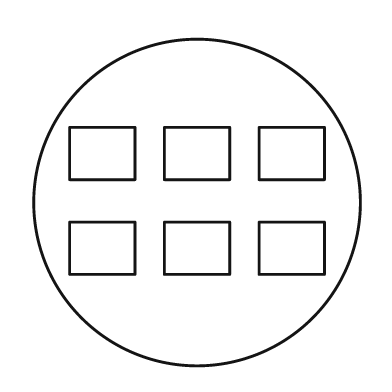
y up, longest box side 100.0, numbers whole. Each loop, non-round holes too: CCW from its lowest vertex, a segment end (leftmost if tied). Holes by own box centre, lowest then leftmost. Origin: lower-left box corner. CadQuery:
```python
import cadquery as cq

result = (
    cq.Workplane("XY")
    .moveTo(50.0, 50.0)
    .circle(50.0)
    .moveTo(11.0, 28.0)
    .lineTo(31.0, 28.0)
    .lineTo(31.0, 44.0)
    .lineTo(11.0, 44.0)
    .close()
    .moveTo(40.0, 28.0)
    .lineTo(60.0, 28.0)
    .lineTo(60.0, 44.0)
    .lineTo(40.0, 44.0)
    .close()
    .moveTo(69.0, 28.0)
    .lineTo(89.0, 28.0)
    .lineTo(89.0, 44.0)
    .lineTo(69.0, 44.0)
    .close()
    .moveTo(11.0, 57.0)
    .lineTo(31.0, 57.0)
    .lineTo(31.0, 73.0)
    .lineTo(11.0, 73.0)
    .close()
    .moveTo(40.0, 57.0)
    .lineTo(60.0, 57.0)
    .lineTo(60.0, 73.0)
    .lineTo(40.0, 73.0)
    .close()
    .moveTo(69.0, 57.0)
    .lineTo(89.0, 57.0)
    .lineTo(89.0, 73.0)
    .lineTo(69.0, 73.0)
    .close()
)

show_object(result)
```